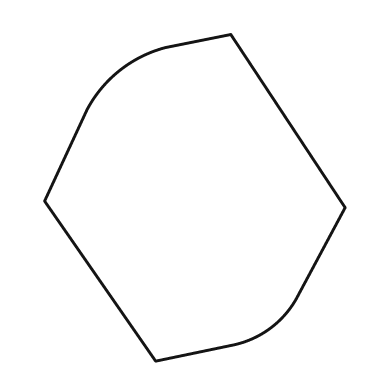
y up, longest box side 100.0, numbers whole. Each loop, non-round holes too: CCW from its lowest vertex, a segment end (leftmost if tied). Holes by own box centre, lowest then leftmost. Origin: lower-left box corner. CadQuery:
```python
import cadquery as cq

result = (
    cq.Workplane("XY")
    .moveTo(34.0, 0.0)
    .lineTo(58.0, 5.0)
    .threePointArc((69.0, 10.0), (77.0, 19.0))
    .lineTo(92.0, 47.0)
    .lineTo(57.0, 100.0)
    .lineTo(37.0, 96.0)
    .threePointArc((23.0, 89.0), (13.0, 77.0))
    .lineTo(0.0, 49.0)
    .close()
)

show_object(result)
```